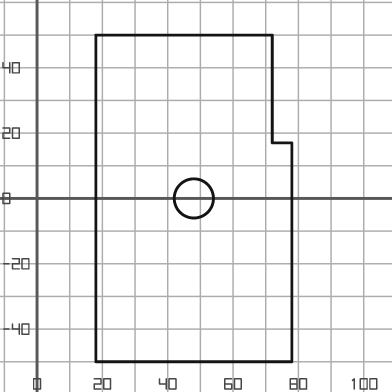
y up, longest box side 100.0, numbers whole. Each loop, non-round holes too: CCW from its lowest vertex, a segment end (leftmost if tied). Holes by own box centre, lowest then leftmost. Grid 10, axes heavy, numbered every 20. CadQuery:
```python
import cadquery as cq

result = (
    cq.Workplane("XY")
    .moveTo(18.0, -50.0)
    .lineTo(78.0, -50.0)
    .lineTo(78.0, 17.0)
    .lineTo(72.0, 17.0)
    .lineTo(72.0, 50.0)
    .lineTo(18.0, 50.0)
    .close()
    .moveTo(48.0, 0.0)
    .circle(6.0)
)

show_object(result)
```